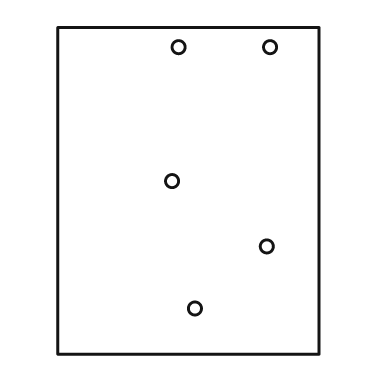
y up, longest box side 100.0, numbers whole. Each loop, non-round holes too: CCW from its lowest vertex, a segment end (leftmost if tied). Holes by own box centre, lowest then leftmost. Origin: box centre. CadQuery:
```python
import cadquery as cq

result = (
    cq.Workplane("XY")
    .moveTo(-40.0, -50.0)
    .lineTo(40.0, -50.0)
    .lineTo(40.0, 50.0)
    .lineTo(-40.0, 50.0)
    .close()
    .moveTo(2.0, -36.0)
    .circle(2.0)
    .moveTo(24.0, -17.0)
    .circle(2.0)
    .moveTo(-5.0, 3.0)
    .circle(2.0)
    .moveTo(-3.0, 44.0)
    .circle(2.0)
    .moveTo(25.0, 44.0)
    .circle(2.0)
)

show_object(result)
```